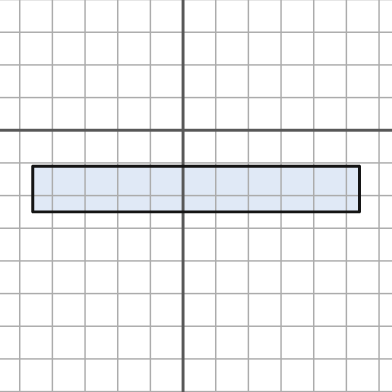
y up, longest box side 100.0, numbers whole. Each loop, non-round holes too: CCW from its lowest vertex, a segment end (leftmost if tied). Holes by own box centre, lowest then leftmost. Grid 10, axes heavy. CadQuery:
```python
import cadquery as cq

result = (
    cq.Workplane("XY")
    .moveTo(-46.0, -25.0)
    .lineTo(54.0, -25.0)
    .lineTo(54.0, -11.0)
    .lineTo(-46.0, -11.0)
    .close()
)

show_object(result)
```